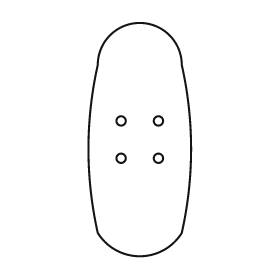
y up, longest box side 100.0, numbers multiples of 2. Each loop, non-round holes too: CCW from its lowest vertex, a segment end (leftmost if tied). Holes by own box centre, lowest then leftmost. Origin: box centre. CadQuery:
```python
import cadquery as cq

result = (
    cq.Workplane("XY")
    .moveTo(-18.0, -40.0)
    .threePointArc((0.0, -50.0), (18.0, -40.0))
    .threePointArc((22.0, -4.0), (18.0, 32.0))
    .threePointArc((0.0, 50.0), (-18.0, 32.0))
    .threePointArc((-22.0, -4.0), (-18.0, -40.0))
    .close()
    .moveTo(-8.0, -8.0)
    .circle(2.0)
    .moveTo(8.0, -8.0)
    .circle(2.0)
    .moveTo(-8.0, 8.0)
    .circle(2.0)
    .moveTo(8.0, 8.0)
    .circle(2.0)
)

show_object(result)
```